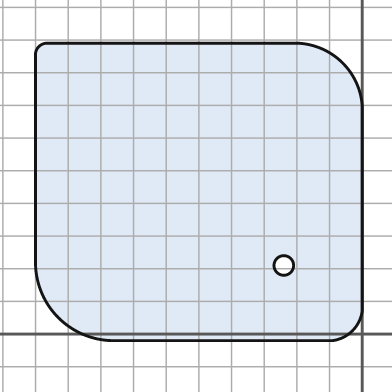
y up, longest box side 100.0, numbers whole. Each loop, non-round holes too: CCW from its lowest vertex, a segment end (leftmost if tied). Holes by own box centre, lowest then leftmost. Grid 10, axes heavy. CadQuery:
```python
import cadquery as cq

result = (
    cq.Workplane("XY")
    .moveTo(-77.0, -2.0)
    .lineTo(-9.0, -2.0)
    .threePointArc((-3.0, 1.0), (0.0, 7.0))
    .lineTo(0.0, 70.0)
    .threePointArc((-6.0, 83.0), (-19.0, 89.0))
    .lineTo(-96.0, 89.0)
    .threePointArc((-99.0, 88.0), (-100.0, 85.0))
    .lineTo(-100.0, 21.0)
    .threePointArc((-93.0, 5.0), (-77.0, -2.0))
    .close()
    .moveTo(-24.0, 21.0)
    .circle(3.0)
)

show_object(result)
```